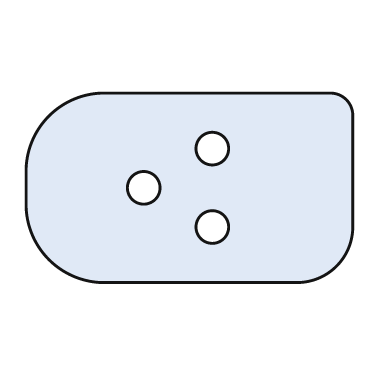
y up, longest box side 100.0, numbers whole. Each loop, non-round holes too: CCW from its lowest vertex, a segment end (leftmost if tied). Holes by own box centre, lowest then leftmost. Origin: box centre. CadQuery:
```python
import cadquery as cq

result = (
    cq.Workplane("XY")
    .moveTo(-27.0, -29.0)
    .lineTo(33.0, -29.0)
    .threePointArc((45.0, -24.0), (50.0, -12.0))
    .lineTo(50.0, 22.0)
    .threePointArc((48.0, 27.0), (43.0, 29.0))
    .lineTo(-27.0, 29.0)
    .threePointArc((-43.0, 22.0), (-50.0, 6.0))
    .lineTo(-50.0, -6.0)
    .threePointArc((-43.0, -22.0), (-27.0, -29.0))
    .close()
    .moveTo(7.0, -12.0)
    .circle(5.0)
    .moveTo(-14.0, 0.0)
    .circle(5.0)
    .moveTo(7.0, 12.0)
    .circle(5.0)
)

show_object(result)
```